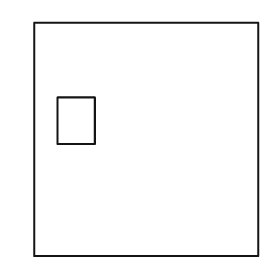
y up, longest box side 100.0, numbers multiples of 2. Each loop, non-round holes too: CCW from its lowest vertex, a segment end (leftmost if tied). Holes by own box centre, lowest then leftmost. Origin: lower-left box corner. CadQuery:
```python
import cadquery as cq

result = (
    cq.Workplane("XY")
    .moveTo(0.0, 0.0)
    .lineTo(96.0, 0.0)
    .lineTo(96.0, 100.0)
    .lineTo(0.0, 100.0)
    .close()
    .moveTo(10.0, 48.0)
    .lineTo(26.0, 48.0)
    .lineTo(26.0, 68.0)
    .lineTo(10.0, 68.0)
    .close()
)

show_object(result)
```